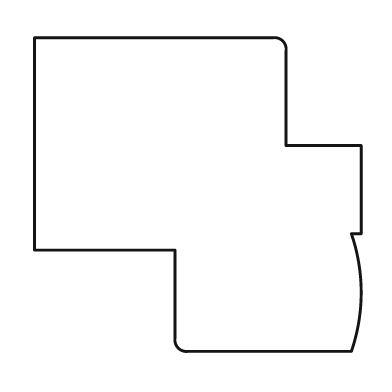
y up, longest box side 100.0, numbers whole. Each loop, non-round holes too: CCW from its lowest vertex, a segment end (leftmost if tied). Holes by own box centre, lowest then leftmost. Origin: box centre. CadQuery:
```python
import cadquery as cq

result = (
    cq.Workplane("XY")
    .moveTo(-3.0, -48.0)
    .lineTo(47.0, -48.0)
    .threePointArc((50.0, -30.0), (47.0, -12.0))
    .lineTo(50.0, -12.0)
    .lineTo(50.0, 15.0)
    .lineTo(27.0, 15.0)
    .lineTo(27.0, 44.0)
    .threePointArc((26.0, 47.0), (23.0, 48.0))
    .lineTo(-50.0, 48.0)
    .lineTo(-50.0, -17.0)
    .lineTo(-7.0, -17.0)
    .lineTo(-7.0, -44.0)
    .threePointArc((-6.0, -47.0), (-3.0, -48.0))
    .close()
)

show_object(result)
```